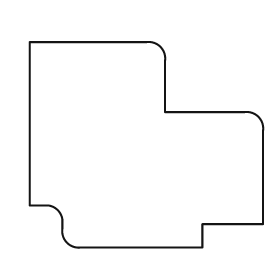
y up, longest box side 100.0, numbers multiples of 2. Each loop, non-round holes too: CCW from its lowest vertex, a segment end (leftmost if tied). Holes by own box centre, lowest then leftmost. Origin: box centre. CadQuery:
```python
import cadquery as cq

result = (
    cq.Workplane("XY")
    .moveTo(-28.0, -44.0)
    .lineTo(24.0, -44.0)
    .lineTo(24.0, -34.0)
    .lineTo(50.0, -34.0)
    .lineTo(50.0, 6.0)
    .threePointArc((48.0, 12.0), (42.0, 14.0))
    .lineTo(8.0, 14.0)
    .lineTo(8.0, 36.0)
    .threePointArc((6.0, 42.0), (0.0, 44.0))
    .lineTo(-50.0, 44.0)
    .lineTo(-50.0, -26.0)
    .lineTo(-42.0, -26.0)
    .threePointArc((-38.0, -28.0), (-36.0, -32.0))
    .lineTo(-36.0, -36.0)
    .threePointArc((-34.0, -42.0), (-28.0, -44.0))
    .close()
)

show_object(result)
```